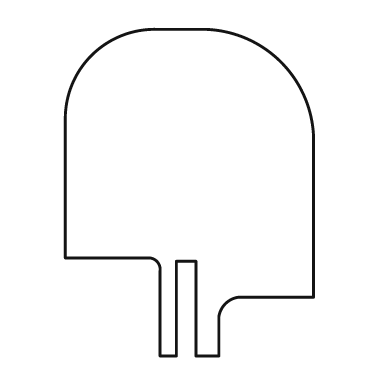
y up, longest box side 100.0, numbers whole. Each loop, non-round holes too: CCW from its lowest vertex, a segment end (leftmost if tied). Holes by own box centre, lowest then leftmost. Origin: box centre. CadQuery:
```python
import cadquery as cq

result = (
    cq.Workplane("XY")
    .moveTo(-9.0, -50.0)
    .lineTo(-4.0, -50.0)
    .lineTo(-4.0, -21.0)
    .lineTo(2.0, -21.0)
    .lineTo(2.0, -50.0)
    .lineTo(9.0, -50.0)
    .lineTo(9.0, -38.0)
    .threePointArc((11.0, -34.0), (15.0, -32.0))
    .lineTo(38.0, -32.0)
    .lineTo(38.0, 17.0)
    .threePointArc((28.0, 40.0), (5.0, 50.0))
    .lineTo(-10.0, 50.0)
    .threePointArc((-30.0, 42.0), (-38.0, 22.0))
    .lineTo(-38.0, -20.0)
    .lineTo(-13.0, -20.0)
    .threePointArc((-10.0, -21.0), (-9.0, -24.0))
    .close()
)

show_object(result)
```